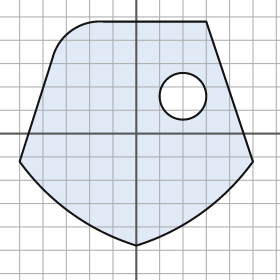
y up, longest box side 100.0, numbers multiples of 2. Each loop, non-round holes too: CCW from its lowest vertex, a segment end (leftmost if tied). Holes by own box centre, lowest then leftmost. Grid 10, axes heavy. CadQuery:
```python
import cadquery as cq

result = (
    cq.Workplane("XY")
    .moveTo(0.0, -48.0)
    .threePointArc((28.0, -34.0), (50.0, -12.0))
    .lineTo(30.0, 48.0)
    .lineTo(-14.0, 48.0)
    .threePointArc((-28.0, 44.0), (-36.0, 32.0))
    .lineTo(-50.0, -12.0)
    .threePointArc((-28.0, -34.0), (0.0, -48.0))
    .close()
    .moveTo(20.0, 16.0)
    .circle(10.0)
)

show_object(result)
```